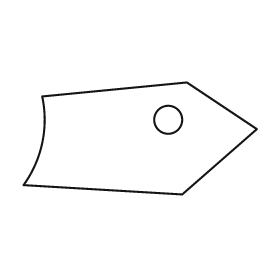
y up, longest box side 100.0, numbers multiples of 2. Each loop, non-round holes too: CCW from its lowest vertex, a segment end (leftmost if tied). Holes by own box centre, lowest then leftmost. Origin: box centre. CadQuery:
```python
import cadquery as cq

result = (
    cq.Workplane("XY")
    .moveTo(18.0, -24.0)
    .lineTo(50.0, 4.0)
    .lineTo(20.0, 24.0)
    .lineTo(-42.0, 18.0)
    .threePointArc((-42.0, -2.0), (-50.0, -20.0))
    .close()
    .moveTo(12.0, 8.0)
    .circle(6.0)
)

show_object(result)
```